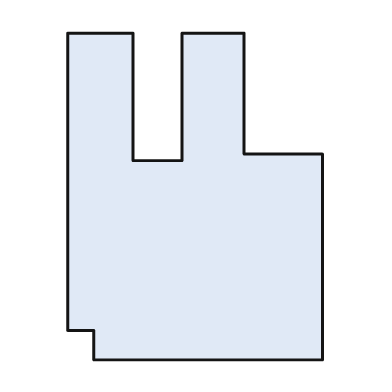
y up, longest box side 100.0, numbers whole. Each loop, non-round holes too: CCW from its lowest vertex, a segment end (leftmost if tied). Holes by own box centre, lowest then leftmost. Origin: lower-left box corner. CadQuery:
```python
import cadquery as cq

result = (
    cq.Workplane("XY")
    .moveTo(8.0, 0.0)
    .lineTo(78.0, 0.0)
    .lineTo(78.0, 63.0)
    .lineTo(54.0, 63.0)
    .lineTo(54.0, 100.0)
    .lineTo(35.0, 100.0)
    .lineTo(35.0, 61.0)
    .lineTo(20.0, 61.0)
    .lineTo(20.0, 100.0)
    .lineTo(0.0, 100.0)
    .lineTo(0.0, 9.0)
    .lineTo(8.0, 9.0)
    .close()
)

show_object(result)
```